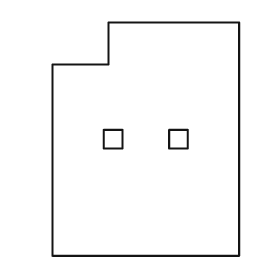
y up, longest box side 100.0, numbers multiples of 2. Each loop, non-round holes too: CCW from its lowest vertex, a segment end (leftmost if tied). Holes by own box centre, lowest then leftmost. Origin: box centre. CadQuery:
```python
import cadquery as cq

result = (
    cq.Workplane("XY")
    .moveTo(-40.0, -50.0)
    .lineTo(40.0, -50.0)
    .lineTo(40.0, 50.0)
    .lineTo(-16.0, 50.0)
    .lineTo(-16.0, 32.0)
    .lineTo(-40.0, 32.0)
    .close()
    .moveTo(-18.0, -4.0)
    .lineTo(-10.0, -4.0)
    .lineTo(-10.0, 4.0)
    .lineTo(-18.0, 4.0)
    .close()
    .moveTo(10.0, -4.0)
    .lineTo(18.0, -4.0)
    .lineTo(18.0, 4.0)
    .lineTo(10.0, 4.0)
    .close()
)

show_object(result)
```